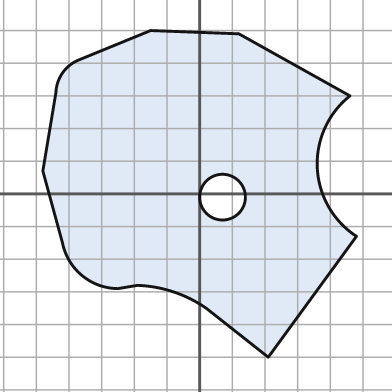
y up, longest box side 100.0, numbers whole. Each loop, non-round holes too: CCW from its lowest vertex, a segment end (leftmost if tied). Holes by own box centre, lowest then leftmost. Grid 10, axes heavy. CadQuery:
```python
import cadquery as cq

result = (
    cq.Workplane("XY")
    .moveTo(21.0, -50.0)
    .lineTo(48.0, -13.0)
    .threePointArc((36.0, 8.0), (46.0, 30.0))
    .lineTo(12.0, 49.0)
    .lineTo(-15.0, 50.0)
    .lineTo(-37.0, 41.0)
    .threePointArc((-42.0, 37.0), (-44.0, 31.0))
    .lineTo(-48.0, 7.0)
    .lineTo(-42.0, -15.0)
    .threePointArc((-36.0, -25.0), (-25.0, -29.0))
    .lineTo(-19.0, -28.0)
    .threePointArc((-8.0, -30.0), (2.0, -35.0))
    .close()
    .moveTo(7.0, -1.0)
    .circle(7.0)
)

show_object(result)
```